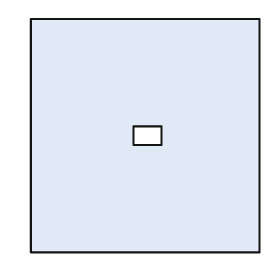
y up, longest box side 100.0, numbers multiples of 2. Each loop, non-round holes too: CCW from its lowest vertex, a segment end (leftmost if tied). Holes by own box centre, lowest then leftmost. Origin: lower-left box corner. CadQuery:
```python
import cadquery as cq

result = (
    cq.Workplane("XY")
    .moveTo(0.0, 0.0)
    .lineTo(98.0, 0.0)
    .lineTo(98.0, 100.0)
    .lineTo(0.0, 100.0)
    .close()
    .moveTo(44.0, 46.0)
    .lineTo(56.0, 46.0)
    .lineTo(56.0, 54.0)
    .lineTo(44.0, 54.0)
    .close()
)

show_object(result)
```